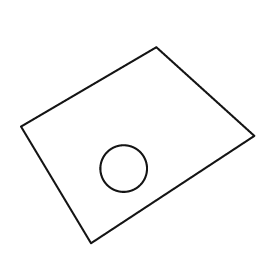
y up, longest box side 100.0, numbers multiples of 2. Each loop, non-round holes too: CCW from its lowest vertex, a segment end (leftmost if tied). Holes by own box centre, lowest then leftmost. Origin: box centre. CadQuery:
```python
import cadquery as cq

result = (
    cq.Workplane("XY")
    .moveTo(-20.0, -42.0)
    .lineTo(50.0, 4.0)
    .lineTo(8.0, 42.0)
    .lineTo(-50.0, 8.0)
    .close()
    .moveTo(-6.0, -10.0)
    .circle(10.0)
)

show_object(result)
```